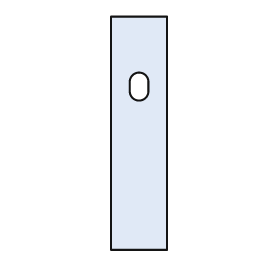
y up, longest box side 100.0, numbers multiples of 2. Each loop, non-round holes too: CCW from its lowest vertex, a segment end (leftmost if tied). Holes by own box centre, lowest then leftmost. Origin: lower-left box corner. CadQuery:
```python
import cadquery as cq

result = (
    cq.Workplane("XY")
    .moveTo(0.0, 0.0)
    .lineTo(24.0, 0.0)
    .lineTo(24.0, 100.0)
    .lineTo(0.0, 100.0)
    .close()
    .moveTo(8.0, 68.0)
    .threePointArc((12.0, 64.0), (16.0, 68.0))
    .lineTo(16.0, 72.0)
    .threePointArc((12.0, 76.0), (8.0, 72.0))
    .close()
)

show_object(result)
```